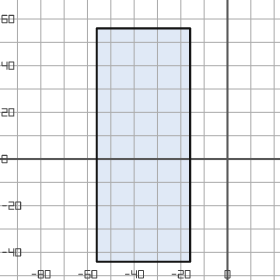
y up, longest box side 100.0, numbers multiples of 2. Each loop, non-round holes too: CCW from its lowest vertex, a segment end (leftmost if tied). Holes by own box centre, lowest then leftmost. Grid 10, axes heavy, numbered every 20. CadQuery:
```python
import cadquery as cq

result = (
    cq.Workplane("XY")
    .moveTo(-56.0, -44.0)
    .lineTo(-16.0, -44.0)
    .lineTo(-16.0, 56.0)
    .lineTo(-56.0, 56.0)
    .close()
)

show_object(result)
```